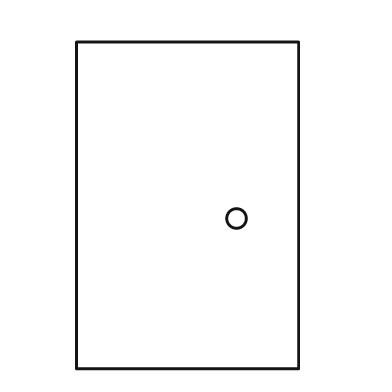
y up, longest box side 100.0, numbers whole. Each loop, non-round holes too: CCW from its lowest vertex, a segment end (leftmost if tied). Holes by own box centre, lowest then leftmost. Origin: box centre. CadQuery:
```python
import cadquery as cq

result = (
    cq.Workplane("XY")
    .moveTo(-34.0, -50.0)
    .lineTo(34.0, -50.0)
    .lineTo(34.0, 50.0)
    .lineTo(-34.0, 50.0)
    .close()
    .moveTo(15.0, -4.0)
    .circle(3.0)
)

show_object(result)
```